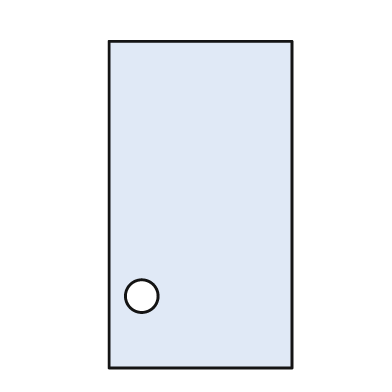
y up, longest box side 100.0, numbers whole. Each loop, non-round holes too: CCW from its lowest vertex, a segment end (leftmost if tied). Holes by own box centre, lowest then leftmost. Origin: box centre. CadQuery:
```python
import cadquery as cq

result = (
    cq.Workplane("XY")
    .moveTo(-28.0, -50.0)
    .lineTo(28.0, -50.0)
    .lineTo(28.0, 50.0)
    .lineTo(-28.0, 50.0)
    .close()
    .moveTo(-18.0, -28.0)
    .circle(5.0)
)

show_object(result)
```